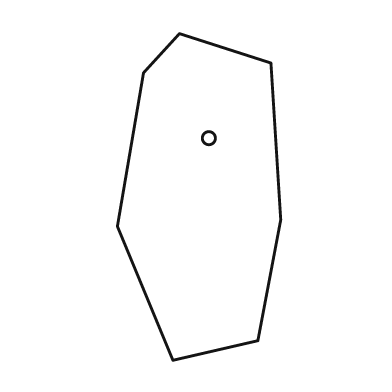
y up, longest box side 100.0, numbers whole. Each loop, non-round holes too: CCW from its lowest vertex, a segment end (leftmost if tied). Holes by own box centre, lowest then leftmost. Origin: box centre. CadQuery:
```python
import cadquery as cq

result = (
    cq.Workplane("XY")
    .moveTo(-8.0, -50.0)
    .lineTo(18.0, -44.0)
    .lineTo(25.0, -7.0)
    .lineTo(22.0, 41.0)
    .lineTo(-6.0, 50.0)
    .lineTo(-17.0, 38.0)
    .lineTo(-25.0, -9.0)
    .close()
    .moveTo(3.0, 18.0)
    .circle(2.0)
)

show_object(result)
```